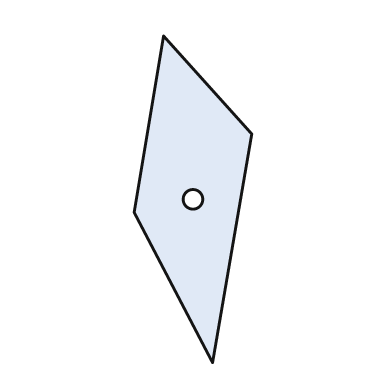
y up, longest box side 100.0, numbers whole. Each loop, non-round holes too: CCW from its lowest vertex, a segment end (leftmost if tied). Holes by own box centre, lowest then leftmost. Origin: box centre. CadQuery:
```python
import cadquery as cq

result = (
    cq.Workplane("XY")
    .moveTo(6.0, -50.0)
    .lineTo(18.0, 20.0)
    .lineTo(-9.0, 50.0)
    .lineTo(-18.0, -4.0)
    .close()
    .moveTo(0.0, 0.0)
    .circle(3.0)
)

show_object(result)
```